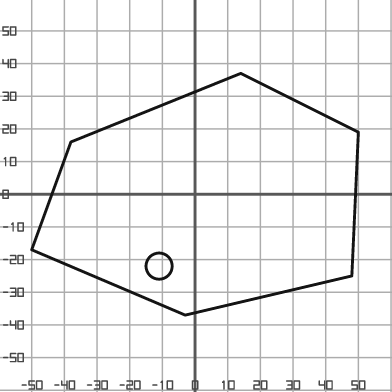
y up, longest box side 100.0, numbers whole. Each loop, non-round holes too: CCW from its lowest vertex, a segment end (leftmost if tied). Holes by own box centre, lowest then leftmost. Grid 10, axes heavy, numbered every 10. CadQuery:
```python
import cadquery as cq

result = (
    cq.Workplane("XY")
    .moveTo(-3.0, -37.0)
    .lineTo(48.0, -25.0)
    .lineTo(50.0, 19.0)
    .lineTo(14.0, 37.0)
    .lineTo(-38.0, 16.0)
    .lineTo(-50.0, -17.0)
    .close()
    .moveTo(-11.0, -22.0)
    .circle(4.0)
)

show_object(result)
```